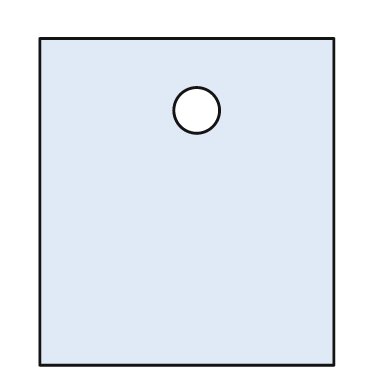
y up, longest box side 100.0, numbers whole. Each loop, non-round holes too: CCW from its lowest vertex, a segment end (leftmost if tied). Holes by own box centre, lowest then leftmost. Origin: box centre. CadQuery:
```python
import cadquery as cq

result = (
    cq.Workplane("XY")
    .moveTo(-45.0, -50.0)
    .lineTo(45.0, -50.0)
    .lineTo(45.0, 50.0)
    .lineTo(-45.0, 50.0)
    .close()
    .moveTo(3.0, 28.0)
    .circle(7.0)
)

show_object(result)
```